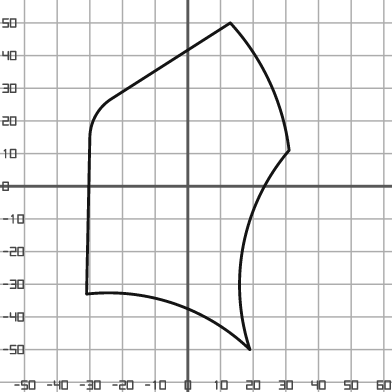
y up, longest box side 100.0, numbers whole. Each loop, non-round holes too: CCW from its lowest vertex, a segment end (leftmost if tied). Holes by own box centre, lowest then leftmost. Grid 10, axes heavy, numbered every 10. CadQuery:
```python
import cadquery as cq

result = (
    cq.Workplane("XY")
    .moveTo(19.0, -50.0)
    .threePointArc((17.0, -18.0), (31.0, 11.0))
    .threePointArc((25.0, 32.0), (13.0, 50.0))
    .lineTo(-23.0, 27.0)
    .threePointArc((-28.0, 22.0), (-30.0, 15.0))
    .lineTo(-31.0, -33.0)
    .threePointArc((-4.0, -36.0), (19.0, -50.0))
    .close()
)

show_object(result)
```